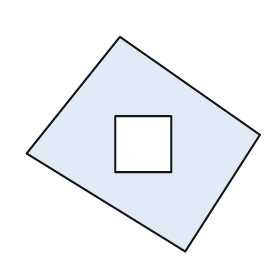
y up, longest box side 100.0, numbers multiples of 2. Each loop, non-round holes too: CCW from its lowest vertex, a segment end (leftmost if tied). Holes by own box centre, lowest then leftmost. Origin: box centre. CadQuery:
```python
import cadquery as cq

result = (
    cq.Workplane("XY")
    .moveTo(18.0, -46.0)
    .lineTo(50.0, 4.0)
    .lineTo(-10.0, 46.0)
    .lineTo(-50.0, -4.0)
    .close()
    .moveTo(-12.0, -12.0)
    .lineTo(12.0, -12.0)
    .lineTo(12.0, 12.0)
    .lineTo(-12.0, 12.0)
    .close()
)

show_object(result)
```